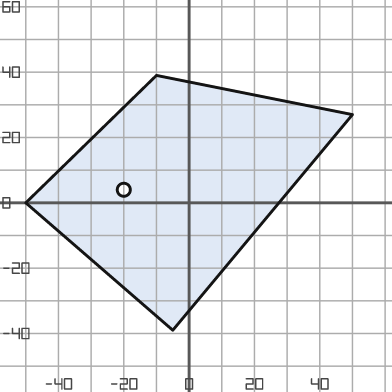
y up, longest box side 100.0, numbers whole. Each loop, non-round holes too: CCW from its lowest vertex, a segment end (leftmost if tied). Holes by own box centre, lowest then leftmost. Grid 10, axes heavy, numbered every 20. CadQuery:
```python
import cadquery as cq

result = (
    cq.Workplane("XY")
    .moveTo(-5.0, -39.0)
    .lineTo(50.0, 27.0)
    .lineTo(-10.0, 39.0)
    .lineTo(-50.0, 0.0)
    .close()
    .moveTo(-20.0, 4.0)
    .circle(2.0)
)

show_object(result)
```